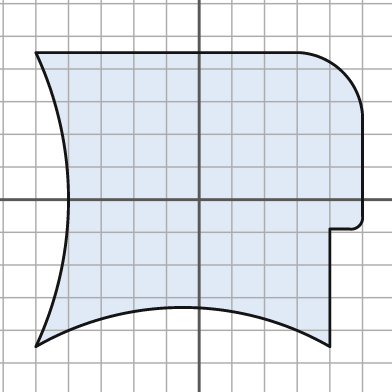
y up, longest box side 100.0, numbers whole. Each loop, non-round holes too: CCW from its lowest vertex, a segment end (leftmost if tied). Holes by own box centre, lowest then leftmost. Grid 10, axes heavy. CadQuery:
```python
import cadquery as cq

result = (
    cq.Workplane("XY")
    .moveTo(-50.0, -45.0)
    .threePointArc((-5.0, -33.0), (40.0, -45.0))
    .lineTo(40.0, -9.0)
    .lineTo(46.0, -9.0)
    .threePointArc((49.0, -8.0), (50.0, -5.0))
    .lineTo(50.0, 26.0)
    .threePointArc((44.0, 39.0), (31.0, 45.0))
    .lineTo(-50.0, 45.0)
    .threePointArc((-40.0, 0.0), (-50.0, -45.0))
    .close()
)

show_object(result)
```